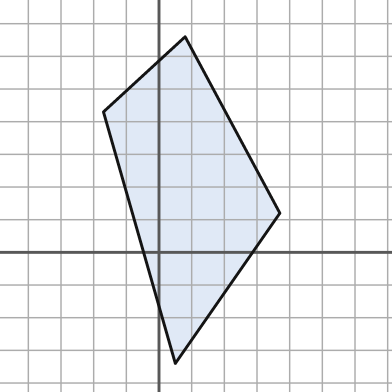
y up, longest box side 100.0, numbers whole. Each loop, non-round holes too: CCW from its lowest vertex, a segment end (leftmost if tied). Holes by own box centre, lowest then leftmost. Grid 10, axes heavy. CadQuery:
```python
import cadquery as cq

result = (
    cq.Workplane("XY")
    .moveTo(5.0, -34.0)
    .lineTo(37.0, 12.0)
    .lineTo(8.0, 66.0)
    .lineTo(-17.0, 43.0)
    .close()
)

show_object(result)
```